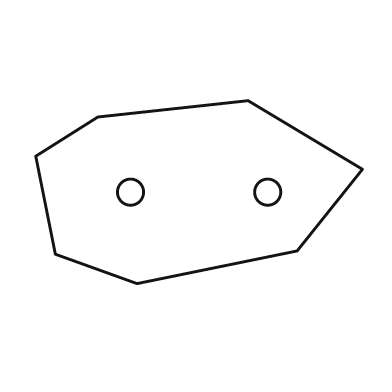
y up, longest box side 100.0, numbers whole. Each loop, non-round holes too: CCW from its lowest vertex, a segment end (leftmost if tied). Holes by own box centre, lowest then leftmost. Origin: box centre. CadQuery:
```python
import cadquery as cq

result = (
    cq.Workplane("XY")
    .moveTo(-19.0, -28.0)
    .lineTo(30.0, -18.0)
    .lineTo(50.0, 7.0)
    .lineTo(15.0, 28.0)
    .lineTo(-31.0, 23.0)
    .lineTo(-50.0, 11.0)
    .lineTo(-44.0, -19.0)
    .close()
    .moveTo(-21.0, 0.0)
    .circle(4.0)
    .moveTo(21.0, 0.0)
    .circle(4.0)
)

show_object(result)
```